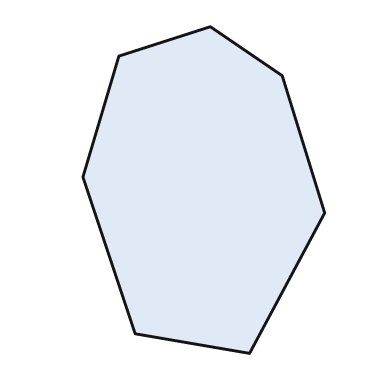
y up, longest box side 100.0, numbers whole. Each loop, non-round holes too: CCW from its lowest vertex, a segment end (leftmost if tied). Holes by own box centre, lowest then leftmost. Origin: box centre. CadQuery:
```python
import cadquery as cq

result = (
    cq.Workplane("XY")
    .moveTo(14.0, -50.0)
    .lineTo(37.0, -7.0)
    .lineTo(24.0, 35.0)
    .lineTo(2.0, 50.0)
    .lineTo(-26.0, 41.0)
    .lineTo(-37.0, 4.0)
    .lineTo(-21.0, -44.0)
    .close()
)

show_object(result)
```